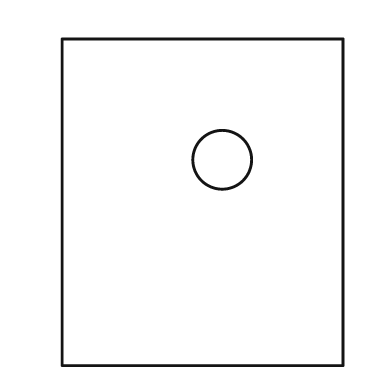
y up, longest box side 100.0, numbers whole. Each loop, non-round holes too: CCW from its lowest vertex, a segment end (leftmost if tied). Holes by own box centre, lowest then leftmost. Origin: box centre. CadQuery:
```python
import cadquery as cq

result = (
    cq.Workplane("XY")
    .moveTo(-43.0, -50.0)
    .lineTo(43.0, -50.0)
    .lineTo(43.0, 50.0)
    .lineTo(-43.0, 50.0)
    .close()
    .moveTo(6.0, 13.0)
    .circle(9.0)
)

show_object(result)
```